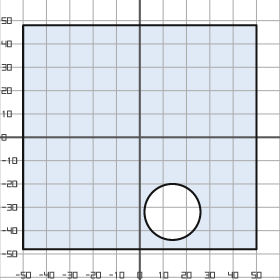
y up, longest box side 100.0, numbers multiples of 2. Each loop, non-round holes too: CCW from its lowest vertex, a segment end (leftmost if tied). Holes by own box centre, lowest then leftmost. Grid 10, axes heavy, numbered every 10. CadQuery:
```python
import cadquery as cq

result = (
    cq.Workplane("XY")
    .moveTo(-50.0, -48.0)
    .lineTo(50.0, -48.0)
    .lineTo(50.0, 48.0)
    .lineTo(-50.0, 48.0)
    .close()
    .moveTo(14.0, -32.0)
    .circle(12.0)
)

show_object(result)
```